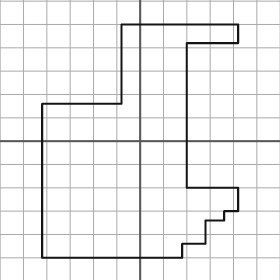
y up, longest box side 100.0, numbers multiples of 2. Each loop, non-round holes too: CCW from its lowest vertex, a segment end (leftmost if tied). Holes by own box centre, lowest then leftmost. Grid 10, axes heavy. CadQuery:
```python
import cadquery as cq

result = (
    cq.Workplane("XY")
    .moveTo(-42.0, -50.0)
    .lineTo(18.0, -50.0)
    .lineTo(18.0, -44.0)
    .lineTo(28.0, -44.0)
    .lineTo(28.0, -34.0)
    .lineTo(36.0, -34.0)
    .lineTo(36.0, -30.0)
    .lineTo(42.0, -30.0)
    .lineTo(42.0, -20.0)
    .lineTo(20.0, -20.0)
    .lineTo(20.0, 42.0)
    .lineTo(42.0, 42.0)
    .lineTo(42.0, 50.0)
    .lineTo(-8.0, 50.0)
    .lineTo(-8.0, 16.0)
    .lineTo(-42.0, 16.0)
    .close()
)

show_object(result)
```